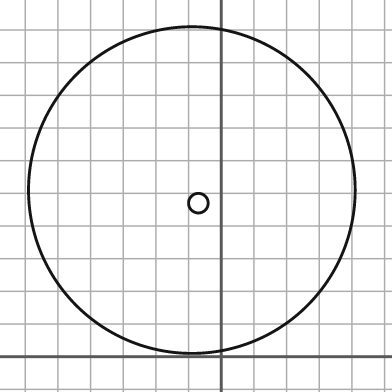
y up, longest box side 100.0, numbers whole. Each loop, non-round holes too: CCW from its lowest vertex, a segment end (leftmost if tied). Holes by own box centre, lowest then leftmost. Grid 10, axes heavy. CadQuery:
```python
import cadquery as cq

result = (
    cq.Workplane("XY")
    .moveTo(-9.0, 51.0)
    .circle(50.0)
    .moveTo(-7.0, 47.0)
    .circle(3.0)
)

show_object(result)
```